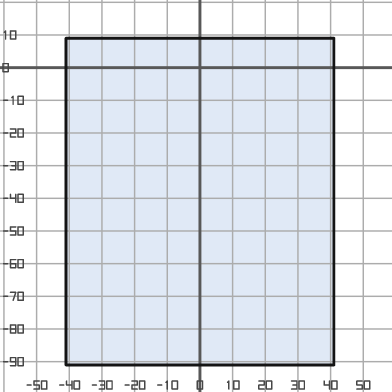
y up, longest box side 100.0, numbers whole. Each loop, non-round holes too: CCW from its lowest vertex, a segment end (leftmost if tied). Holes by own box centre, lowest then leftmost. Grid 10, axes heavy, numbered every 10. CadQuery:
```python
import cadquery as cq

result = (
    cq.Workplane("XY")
    .moveTo(-41.0, -91.0)
    .lineTo(41.0, -91.0)
    .lineTo(41.0, 9.0)
    .lineTo(-41.0, 9.0)
    .close()
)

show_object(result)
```